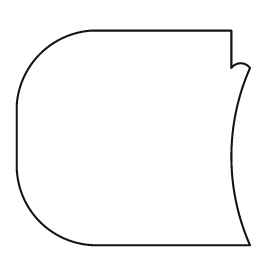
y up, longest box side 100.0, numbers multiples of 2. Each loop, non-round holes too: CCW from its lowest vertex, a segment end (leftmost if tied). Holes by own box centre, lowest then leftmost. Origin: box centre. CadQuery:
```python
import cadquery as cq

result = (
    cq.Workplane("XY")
    .moveTo(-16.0, -46.0)
    .lineTo(50.0, -46.0)
    .threePointArc((42.0, -8.0), (50.0, 30.0))
    .threePointArc((46.0, 32.0), (42.0, 30.0))
    .lineTo(42.0, 46.0)
    .lineTo(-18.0, 46.0)
    .threePointArc((-40.0, 36.0), (-50.0, 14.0))
    .lineTo(-50.0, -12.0)
    .threePointArc((-40.0, -36.0), (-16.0, -46.0))
    .close()
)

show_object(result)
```